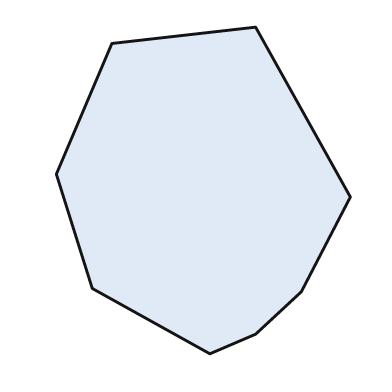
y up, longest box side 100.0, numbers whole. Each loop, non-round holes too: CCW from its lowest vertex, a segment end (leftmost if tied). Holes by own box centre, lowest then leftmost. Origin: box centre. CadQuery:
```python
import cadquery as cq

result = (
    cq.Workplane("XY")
    .moveTo(2.0, -50.0)
    .lineTo(16.0, -44.0)
    .lineTo(30.0, -31.0)
    .lineTo(45.0, -2.0)
    .lineTo(16.0, 50.0)
    .lineTo(-28.0, 45.0)
    .lineTo(-45.0, 5.0)
    .lineTo(-34.0, -30.0)
    .close()
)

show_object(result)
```